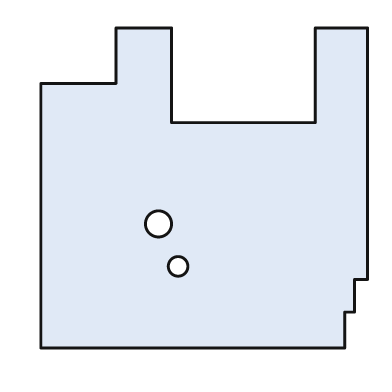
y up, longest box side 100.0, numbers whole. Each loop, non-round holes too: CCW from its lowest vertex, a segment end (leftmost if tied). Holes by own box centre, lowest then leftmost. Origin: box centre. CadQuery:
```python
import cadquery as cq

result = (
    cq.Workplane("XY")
    .moveTo(-50.0, -49.0)
    .lineTo(43.0, -49.0)
    .lineTo(43.0, -38.0)
    .lineTo(46.0, -38.0)
    .lineTo(46.0, -28.0)
    .lineTo(50.0, -28.0)
    .lineTo(50.0, 49.0)
    .lineTo(34.0, 49.0)
    .lineTo(34.0, 20.0)
    .lineTo(-10.0, 20.0)
    .lineTo(-10.0, 49.0)
    .lineTo(-27.0, 49.0)
    .lineTo(-27.0, 32.0)
    .lineTo(-50.0, 32.0)
    .close()
    .moveTo(-8.0, -24.0)
    .circle(3.0)
    .moveTo(-14.0, -11.0)
    .circle(4.0)
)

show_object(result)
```